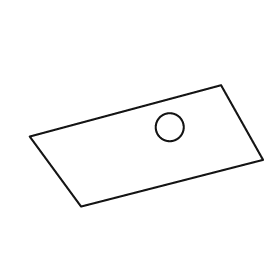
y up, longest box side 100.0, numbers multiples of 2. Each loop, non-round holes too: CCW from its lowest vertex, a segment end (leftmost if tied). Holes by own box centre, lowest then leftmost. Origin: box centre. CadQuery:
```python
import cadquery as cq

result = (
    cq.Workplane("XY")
    .moveTo(-28.0, -26.0)
    .lineTo(50.0, -6.0)
    .lineTo(32.0, 26.0)
    .lineTo(-50.0, 4.0)
    .close()
    .moveTo(10.0, 8.0)
    .circle(6.0)
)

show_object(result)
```